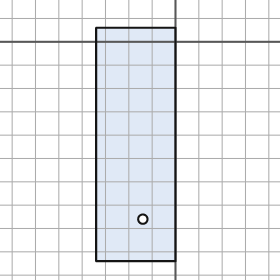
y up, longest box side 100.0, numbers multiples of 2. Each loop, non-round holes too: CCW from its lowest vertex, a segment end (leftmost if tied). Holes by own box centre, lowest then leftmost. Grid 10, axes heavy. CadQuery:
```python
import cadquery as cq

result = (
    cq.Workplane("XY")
    .moveTo(-34.0, -94.0)
    .lineTo(0.0, -94.0)
    .lineTo(0.0, 6.0)
    .lineTo(-34.0, 6.0)
    .close()
    .moveTo(-14.0, -76.0)
    .circle(2.0)
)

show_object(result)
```